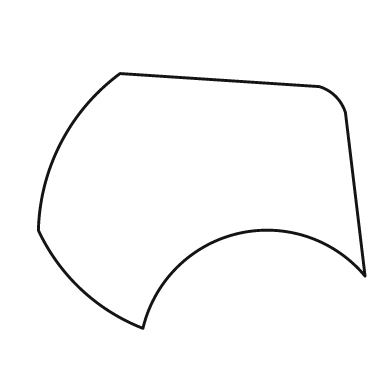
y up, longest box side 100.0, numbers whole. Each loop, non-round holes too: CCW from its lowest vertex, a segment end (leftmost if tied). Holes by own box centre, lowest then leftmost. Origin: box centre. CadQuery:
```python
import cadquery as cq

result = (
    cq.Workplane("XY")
    .moveTo(-18.0, -39.0)
    .threePointArc((11.0, -10.0), (50.0, -23.0))
    .lineTo(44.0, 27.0)
    .threePointArc((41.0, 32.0), (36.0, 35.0))
    .lineTo(-25.0, 39.0)
    .threePointArc((-43.0, 18.0), (-50.0, -9.0))
    .threePointArc((-37.0, -27.0), (-18.0, -39.0))
    .close()
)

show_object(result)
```